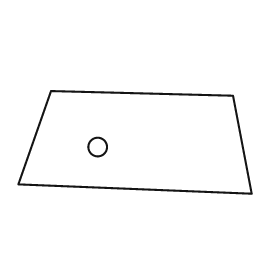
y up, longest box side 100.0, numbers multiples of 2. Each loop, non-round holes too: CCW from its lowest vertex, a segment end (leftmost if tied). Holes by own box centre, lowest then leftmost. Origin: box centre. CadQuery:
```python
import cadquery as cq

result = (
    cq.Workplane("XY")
    .moveTo(50.0, -22.0)
    .lineTo(42.0, 20.0)
    .lineTo(-36.0, 22.0)
    .lineTo(-50.0, -18.0)
    .close()
    .moveTo(-16.0, -2.0)
    .circle(4.0)
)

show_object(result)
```